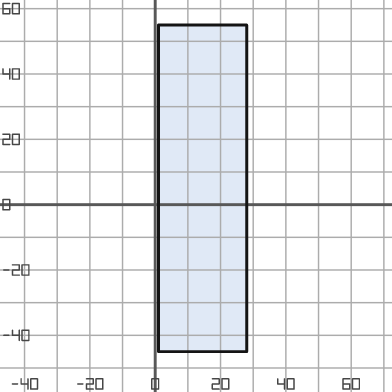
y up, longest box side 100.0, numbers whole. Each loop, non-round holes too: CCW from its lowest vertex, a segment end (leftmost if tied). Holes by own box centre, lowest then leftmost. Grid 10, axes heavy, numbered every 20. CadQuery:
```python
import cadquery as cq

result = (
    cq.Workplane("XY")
    .moveTo(1.0, -45.0)
    .lineTo(28.0, -45.0)
    .lineTo(28.0, 55.0)
    .lineTo(1.0, 55.0)
    .close()
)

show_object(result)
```